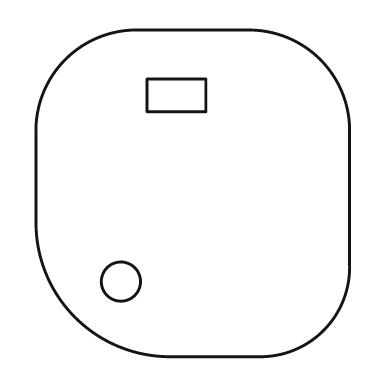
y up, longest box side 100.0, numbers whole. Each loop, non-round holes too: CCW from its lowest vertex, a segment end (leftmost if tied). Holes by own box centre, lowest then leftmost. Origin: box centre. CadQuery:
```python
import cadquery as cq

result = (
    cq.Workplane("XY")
    .moveTo(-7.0, -50.0)
    .lineTo(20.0, -50.0)
    .threePointArc((40.0, -42.0), (48.0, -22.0))
    .lineTo(48.0, 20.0)
    .threePointArc((39.0, 41.0), (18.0, 50.0))
    .lineTo(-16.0, 50.0)
    .threePointArc((-39.0, 41.0), (-48.0, 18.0))
    .lineTo(-48.0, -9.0)
    .threePointArc((-36.0, -38.0), (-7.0, -50.0))
    .close()
    .moveTo(-22.0, -27.0)
    .circle(6.0)
    .moveTo(-14.0, 25.0)
    .lineTo(4.0, 25.0)
    .lineTo(4.0, 35.0)
    .lineTo(-14.0, 35.0)
    .close()
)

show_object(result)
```